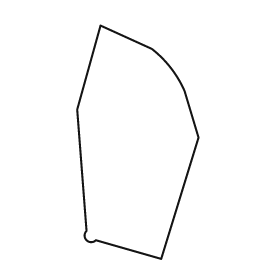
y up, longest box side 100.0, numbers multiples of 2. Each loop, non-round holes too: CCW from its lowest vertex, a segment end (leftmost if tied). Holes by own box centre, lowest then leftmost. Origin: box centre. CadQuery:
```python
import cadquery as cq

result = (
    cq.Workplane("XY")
    .moveTo(10.0, -50.0)
    .lineTo(26.0, 2.0)
    .lineTo(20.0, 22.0)
    .threePointArc((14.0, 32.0), (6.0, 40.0))
    .lineTo(-16.0, 50.0)
    .lineTo(-26.0, 14.0)
    .lineTo(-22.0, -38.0)
    .threePointArc((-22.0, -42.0), (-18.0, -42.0))
    .close()
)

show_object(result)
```